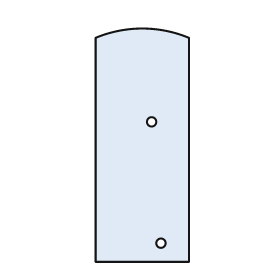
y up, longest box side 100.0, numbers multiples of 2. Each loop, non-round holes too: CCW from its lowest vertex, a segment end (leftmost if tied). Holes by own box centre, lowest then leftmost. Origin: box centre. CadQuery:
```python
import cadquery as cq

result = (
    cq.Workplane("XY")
    .moveTo(-20.0, -50.0)
    .lineTo(20.0, -50.0)
    .lineTo(20.0, 46.0)
    .threePointArc((0.0, 50.0), (-20.0, 46.0))
    .close()
    .moveTo(8.0, -42.0)
    .circle(2.0)
    .moveTo(4.0, 10.0)
    .circle(2.0)
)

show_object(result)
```